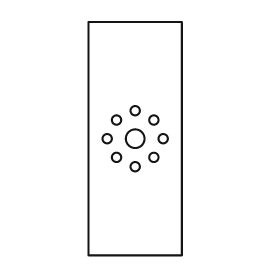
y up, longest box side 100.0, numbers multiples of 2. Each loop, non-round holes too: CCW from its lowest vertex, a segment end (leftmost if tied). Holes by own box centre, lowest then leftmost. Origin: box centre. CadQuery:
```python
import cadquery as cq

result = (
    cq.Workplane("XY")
    .moveTo(-20.0, -50.0)
    .lineTo(20.0, -50.0)
    .lineTo(20.0, 50.0)
    .lineTo(-20.0, 50.0)
    .close()
    .moveTo(0.0, -12.0)
    .circle(2.0)
    .moveTo(-8.0, -8.0)
    .circle(2.0)
    .moveTo(8.0, -8.0)
    .circle(2.0)
    .moveTo(-12.0, 0.0)
    .circle(2.0)
    .moveTo(0.0, 0.0)
    .circle(4.0)
    .moveTo(12.0, 0.0)
    .circle(2.0)
    .moveTo(-8.0, 8.0)
    .circle(2.0)
    .moveTo(8.0, 8.0)
    .circle(2.0)
    .moveTo(0.0, 12.0)
    .circle(2.0)
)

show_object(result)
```